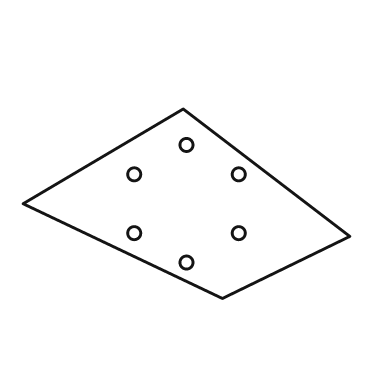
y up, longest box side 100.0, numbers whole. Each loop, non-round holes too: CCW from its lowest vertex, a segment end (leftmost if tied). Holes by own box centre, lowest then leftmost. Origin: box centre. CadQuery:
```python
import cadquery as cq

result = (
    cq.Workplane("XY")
    .moveTo(11.0, -29.0)
    .lineTo(50.0, -10.0)
    .lineTo(-1.0, 29.0)
    .lineTo(-50.0, 0.0)
    .close()
    .moveTo(0.0, -18.0)
    .circle(2.0)
    .moveTo(-16.0, -9.0)
    .circle(2.0)
    .moveTo(16.0, -9.0)
    .circle(2.0)
    .moveTo(-16.0, 9.0)
    .circle(2.0)
    .moveTo(16.0, 9.0)
    .circle(2.0)
    .moveTo(0.0, 18.0)
    .circle(2.0)
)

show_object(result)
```